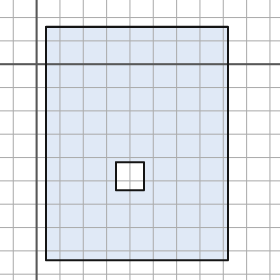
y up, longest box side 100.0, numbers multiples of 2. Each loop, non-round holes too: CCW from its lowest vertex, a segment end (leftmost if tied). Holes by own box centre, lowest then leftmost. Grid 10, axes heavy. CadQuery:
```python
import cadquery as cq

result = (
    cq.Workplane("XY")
    .moveTo(4.0, -84.0)
    .lineTo(82.0, -84.0)
    .lineTo(82.0, 16.0)
    .lineTo(4.0, 16.0)
    .close()
    .moveTo(34.0, -54.0)
    .lineTo(46.0, -54.0)
    .lineTo(46.0, -42.0)
    .lineTo(34.0, -42.0)
    .close()
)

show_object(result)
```